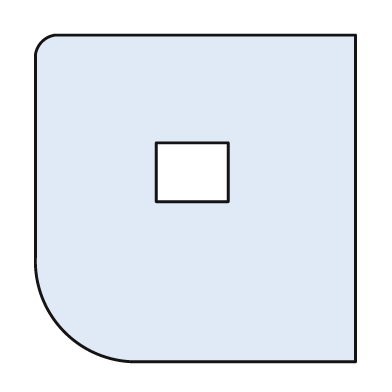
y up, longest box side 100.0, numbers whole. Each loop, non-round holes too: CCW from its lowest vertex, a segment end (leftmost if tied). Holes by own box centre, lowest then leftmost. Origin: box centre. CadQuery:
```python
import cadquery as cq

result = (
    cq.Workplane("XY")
    .moveTo(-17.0, -50.0)
    .lineTo(49.0, -50.0)
    .lineTo(49.0, 50.0)
    .lineTo(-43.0, 50.0)
    .threePointArc((-47.0, 48.0), (-49.0, 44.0))
    .lineTo(-49.0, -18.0)
    .threePointArc((-40.0, -41.0), (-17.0, -50.0))
    .close()
    .moveTo(-12.0, -1.0)
    .lineTo(10.0, -1.0)
    .lineTo(10.0, 17.0)
    .lineTo(-12.0, 17.0)
    .close()
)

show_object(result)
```